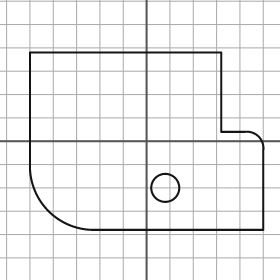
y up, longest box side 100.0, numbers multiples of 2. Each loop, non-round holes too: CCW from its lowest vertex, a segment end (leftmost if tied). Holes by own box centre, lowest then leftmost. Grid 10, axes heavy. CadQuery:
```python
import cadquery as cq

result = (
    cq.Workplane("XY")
    .moveTo(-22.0, -38.0)
    .lineTo(50.0, -38.0)
    .lineTo(50.0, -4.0)
    .threePointArc((48.0, 2.0), (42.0, 4.0))
    .lineTo(32.0, 4.0)
    .lineTo(32.0, 38.0)
    .lineTo(-50.0, 38.0)
    .lineTo(-50.0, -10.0)
    .threePointArc((-42.0, -30.0), (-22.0, -38.0))
    .close()
    .moveTo(8.0, -20.0)
    .circle(6.0)
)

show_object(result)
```